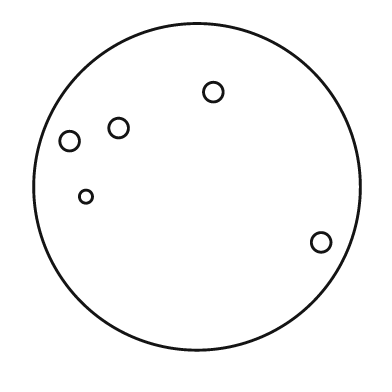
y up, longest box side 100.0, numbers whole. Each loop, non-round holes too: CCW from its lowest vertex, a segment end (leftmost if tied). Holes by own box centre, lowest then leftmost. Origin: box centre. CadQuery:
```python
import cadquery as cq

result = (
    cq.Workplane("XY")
    .moveTo(0.0, 0.0)
    .circle(50.0)
    .moveTo(38.0, -17.0)
    .circle(3.0)
    .moveTo(-34.0, -3.0)
    .circle(2.0)
    .moveTo(-39.0, 14.0)
    .circle(3.0)
    .moveTo(-24.0, 18.0)
    .circle(3.0)
    .moveTo(5.0, 29.0)
    .circle(3.0)
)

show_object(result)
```